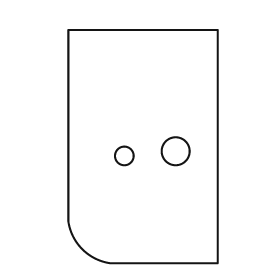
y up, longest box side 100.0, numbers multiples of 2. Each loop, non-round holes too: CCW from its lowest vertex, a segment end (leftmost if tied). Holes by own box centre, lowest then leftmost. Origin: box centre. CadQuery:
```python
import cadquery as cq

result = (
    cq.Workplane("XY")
    .moveTo(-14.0, -50.0)
    .lineTo(32.0, -50.0)
    .lineTo(32.0, 50.0)
    .lineTo(-32.0, 50.0)
    .lineTo(-32.0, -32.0)
    .threePointArc((-26.0, -44.0), (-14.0, -50.0))
    .close()
    .moveTo(-8.0, -4.0)
    .circle(4.0)
    .moveTo(14.0, -2.0)
    .circle(6.0)
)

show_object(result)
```